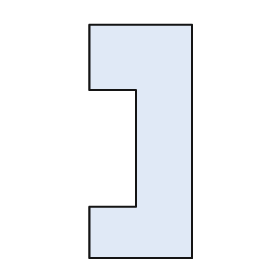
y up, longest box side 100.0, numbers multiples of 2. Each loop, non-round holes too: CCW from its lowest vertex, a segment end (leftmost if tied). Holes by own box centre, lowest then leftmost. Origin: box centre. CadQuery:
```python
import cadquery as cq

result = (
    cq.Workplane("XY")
    .moveTo(-22.0, -50.0)
    .lineTo(22.0, -50.0)
    .lineTo(22.0, 50.0)
    .lineTo(-22.0, 50.0)
    .lineTo(-22.0, 22.0)
    .lineTo(-2.0, 22.0)
    .lineTo(-2.0, -28.0)
    .lineTo(-22.0, -28.0)
    .close()
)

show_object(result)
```